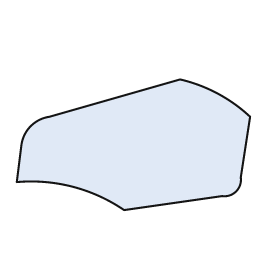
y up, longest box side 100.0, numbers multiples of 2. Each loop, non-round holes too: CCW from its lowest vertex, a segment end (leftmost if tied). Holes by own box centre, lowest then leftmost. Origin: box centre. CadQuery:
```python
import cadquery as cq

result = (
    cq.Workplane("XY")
    .moveTo(-4.0, -28.0)
    .lineTo(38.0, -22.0)
    .threePointArc((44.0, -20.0), (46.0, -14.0))
    .lineTo(50.0, 12.0)
    .threePointArc((36.0, 22.0), (20.0, 28.0))
    .lineTo(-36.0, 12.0)
    .threePointArc((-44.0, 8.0), (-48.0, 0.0))
    .lineTo(-50.0, -16.0)
    .threePointArc((-26.0, -18.0), (-4.0, -28.0))
    .close()
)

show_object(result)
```